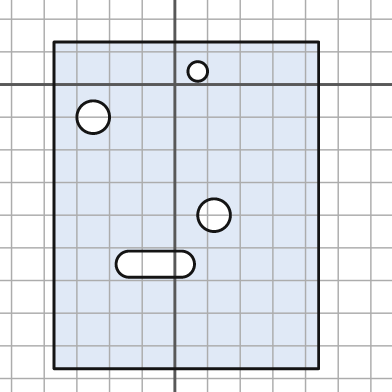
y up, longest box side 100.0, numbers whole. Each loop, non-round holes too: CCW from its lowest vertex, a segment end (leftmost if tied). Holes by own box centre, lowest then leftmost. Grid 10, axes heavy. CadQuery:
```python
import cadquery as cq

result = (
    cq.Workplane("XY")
    .moveTo(-37.0, -87.0)
    .lineTo(44.0, -87.0)
    .lineTo(44.0, 13.0)
    .lineTo(-37.0, 13.0)
    .close()
    .moveTo(-14.0, -59.0)
    .lineTo(2.0, -59.0)
    .threePointArc((6.0, -55.0), (2.0, -51.0))
    .lineTo(-14.0, -51.0)
    .threePointArc((-18.0, -55.0), (-14.0, -59.0))
    .close()
    .moveTo(12.0, -40.0)
    .circle(5.0)
    .moveTo(-25.0, -10.0)
    .circle(5.0)
    .moveTo(7.0, 4.0)
    .circle(3.0)
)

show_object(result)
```